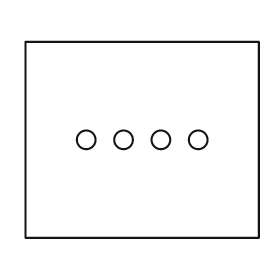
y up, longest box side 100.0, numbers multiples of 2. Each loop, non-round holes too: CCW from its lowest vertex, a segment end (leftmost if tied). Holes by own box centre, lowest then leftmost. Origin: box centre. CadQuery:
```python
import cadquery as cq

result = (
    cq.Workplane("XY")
    .moveTo(-50.0, -42.0)
    .lineTo(50.0, -42.0)
    .lineTo(50.0, 42.0)
    .lineTo(-50.0, 42.0)
    .close()
    .moveTo(-24.0, 0.0)
    .circle(4.0)
    .moveTo(-8.0, 0.0)
    .circle(4.0)
    .moveTo(8.0, 0.0)
    .circle(4.0)
    .moveTo(24.0, 0.0)
    .circle(4.0)
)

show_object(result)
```